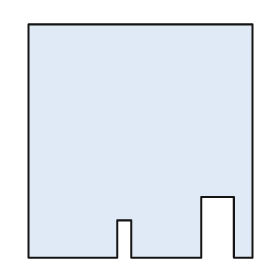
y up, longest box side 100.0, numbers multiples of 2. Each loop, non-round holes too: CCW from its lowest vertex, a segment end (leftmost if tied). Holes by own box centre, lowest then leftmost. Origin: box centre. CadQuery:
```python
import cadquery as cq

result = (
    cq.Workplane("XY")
    .moveTo(-48.0, -50.0)
    .lineTo(-10.0, -50.0)
    .lineTo(-10.0, -34.0)
    .lineTo(-4.0, -34.0)
    .lineTo(-4.0, -50.0)
    .lineTo(26.0, -50.0)
    .lineTo(26.0, -24.0)
    .lineTo(40.0, -24.0)
    .lineTo(40.0, -50.0)
    .lineTo(48.0, -50.0)
    .lineTo(48.0, 50.0)
    .lineTo(-48.0, 50.0)
    .close()
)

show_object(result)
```